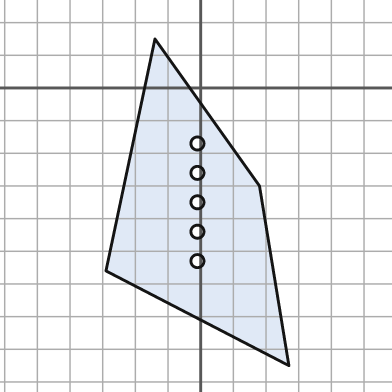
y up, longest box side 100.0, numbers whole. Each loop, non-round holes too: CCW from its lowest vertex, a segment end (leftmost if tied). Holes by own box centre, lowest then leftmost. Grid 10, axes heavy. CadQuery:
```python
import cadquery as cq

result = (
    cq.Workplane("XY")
    .moveTo(27.0, -85.0)
    .lineTo(18.0, -30.0)
    .lineTo(-14.0, 15.0)
    .lineTo(-29.0, -56.0)
    .close()
    .moveTo(-1.0, -53.0)
    .circle(2.0)
    .moveTo(-1.0, -44.0)
    .circle(2.0)
    .moveTo(-1.0, -35.0)
    .circle(2.0)
    .moveTo(-1.0, -26.0)
    .circle(2.0)
    .moveTo(-1.0, -17.0)
    .circle(2.0)
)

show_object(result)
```